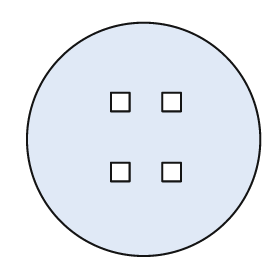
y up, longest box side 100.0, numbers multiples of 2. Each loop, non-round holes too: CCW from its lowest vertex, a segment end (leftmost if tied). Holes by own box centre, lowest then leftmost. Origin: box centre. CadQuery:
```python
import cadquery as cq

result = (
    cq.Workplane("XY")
    .moveTo(0.0, 0.0)
    .circle(50.0)
    .moveTo(-14.0, -18.0)
    .lineTo(-6.0, -18.0)
    .lineTo(-6.0, -10.0)
    .lineTo(-14.0, -10.0)
    .close()
    .moveTo(8.0, -18.0)
    .lineTo(16.0, -18.0)
    .lineTo(16.0, -10.0)
    .lineTo(8.0, -10.0)
    .close()
    .moveTo(-14.0, 12.0)
    .lineTo(-6.0, 12.0)
    .lineTo(-6.0, 20.0)
    .lineTo(-14.0, 20.0)
    .close()
    .moveTo(8.0, 12.0)
    .lineTo(16.0, 12.0)
    .lineTo(16.0, 20.0)
    .lineTo(8.0, 20.0)
    .close()
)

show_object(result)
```